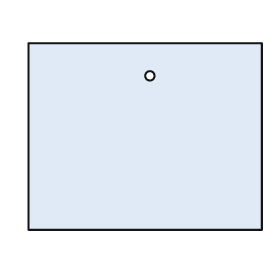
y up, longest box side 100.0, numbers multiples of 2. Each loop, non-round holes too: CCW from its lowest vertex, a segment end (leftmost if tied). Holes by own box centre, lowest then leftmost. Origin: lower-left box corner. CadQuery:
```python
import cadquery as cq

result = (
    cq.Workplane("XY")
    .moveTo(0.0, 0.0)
    .lineTo(100.0, 0.0)
    .lineTo(100.0, 80.0)
    .lineTo(0.0, 80.0)
    .close()
    .moveTo(52.0, 66.0)
    .circle(2.0)
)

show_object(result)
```